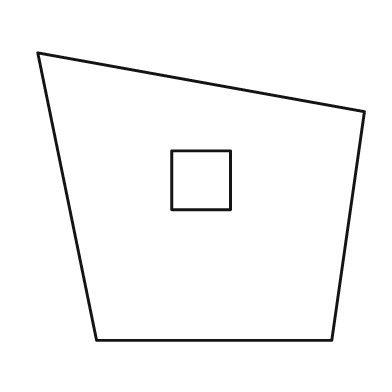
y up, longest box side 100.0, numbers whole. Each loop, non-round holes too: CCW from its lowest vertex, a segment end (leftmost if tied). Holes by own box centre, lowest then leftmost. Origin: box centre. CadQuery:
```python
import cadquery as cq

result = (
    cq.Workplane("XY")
    .moveTo(-32.0, -44.0)
    .lineTo(40.0, -44.0)
    .lineTo(50.0, 26.0)
    .lineTo(-50.0, 44.0)
    .close()
    .moveTo(-9.0, -4.0)
    .lineTo(9.0, -4.0)
    .lineTo(9.0, 14.0)
    .lineTo(-9.0, 14.0)
    .close()
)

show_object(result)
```